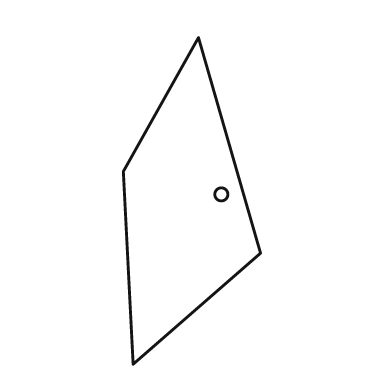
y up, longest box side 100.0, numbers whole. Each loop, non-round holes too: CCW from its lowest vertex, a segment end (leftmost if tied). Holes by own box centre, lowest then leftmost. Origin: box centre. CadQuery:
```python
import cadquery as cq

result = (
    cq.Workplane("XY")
    .moveTo(-18.0, -50.0)
    .lineTo(21.0, -16.0)
    .lineTo(2.0, 50.0)
    .lineTo(-21.0, 9.0)
    .close()
    .moveTo(9.0, 2.0)
    .circle(2.0)
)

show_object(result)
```